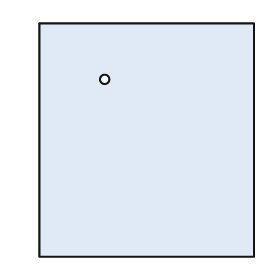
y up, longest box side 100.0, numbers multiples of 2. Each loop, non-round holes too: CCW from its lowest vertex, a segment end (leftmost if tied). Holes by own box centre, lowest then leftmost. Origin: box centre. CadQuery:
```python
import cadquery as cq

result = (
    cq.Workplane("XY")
    .moveTo(-46.0, -50.0)
    .lineTo(46.0, -50.0)
    .lineTo(46.0, 50.0)
    .lineTo(-46.0, 50.0)
    .close()
    .moveTo(-18.0, 26.0)
    .circle(2.0)
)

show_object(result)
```